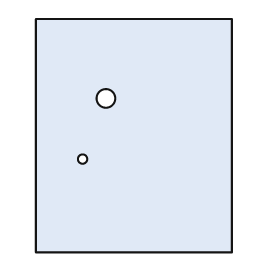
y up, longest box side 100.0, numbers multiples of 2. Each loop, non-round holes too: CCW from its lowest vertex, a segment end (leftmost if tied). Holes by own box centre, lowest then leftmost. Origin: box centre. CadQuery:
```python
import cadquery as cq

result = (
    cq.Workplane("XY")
    .moveTo(-42.0, -50.0)
    .lineTo(42.0, -50.0)
    .lineTo(42.0, 50.0)
    .lineTo(-42.0, 50.0)
    .close()
    .moveTo(-22.0, -10.0)
    .circle(2.0)
    .moveTo(-12.0, 16.0)
    .circle(4.0)
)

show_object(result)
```